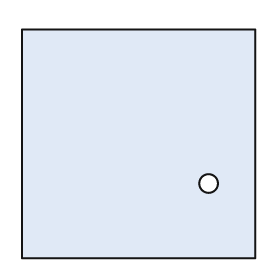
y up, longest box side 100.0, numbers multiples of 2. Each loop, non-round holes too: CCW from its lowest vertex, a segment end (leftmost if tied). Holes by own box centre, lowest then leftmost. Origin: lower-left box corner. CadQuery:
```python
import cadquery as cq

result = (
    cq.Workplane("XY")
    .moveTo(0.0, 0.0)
    .lineTo(100.0, 0.0)
    .lineTo(100.0, 98.0)
    .lineTo(0.0, 98.0)
    .close()
    .moveTo(80.0, 32.0)
    .circle(4.0)
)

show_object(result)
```